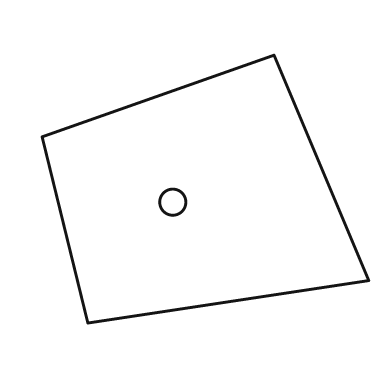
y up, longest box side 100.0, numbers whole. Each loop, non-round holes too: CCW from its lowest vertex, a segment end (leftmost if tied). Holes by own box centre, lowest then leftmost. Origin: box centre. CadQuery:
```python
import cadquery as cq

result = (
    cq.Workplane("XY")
    .moveTo(-36.0, -41.0)
    .lineTo(50.0, -28.0)
    .lineTo(21.0, 41.0)
    .lineTo(-50.0, 16.0)
    .close()
    .moveTo(-10.0, -4.0)
    .circle(4.0)
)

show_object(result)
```